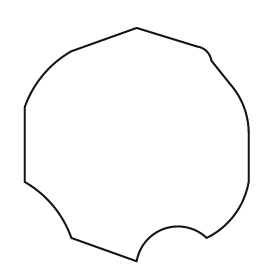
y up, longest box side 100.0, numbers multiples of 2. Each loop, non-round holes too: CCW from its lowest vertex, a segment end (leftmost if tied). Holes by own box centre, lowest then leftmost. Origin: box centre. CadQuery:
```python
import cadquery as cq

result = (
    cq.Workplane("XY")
    .moveTo(0.0, -50.0)
    .threePointArc((12.0, -36.0), (30.0, -40.0))
    .threePointArc((42.0, -30.0), (48.0, -16.0))
    .lineTo(48.0, 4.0)
    .threePointArc((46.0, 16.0), (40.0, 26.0))
    .lineTo(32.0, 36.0)
    .threePointArc((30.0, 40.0), (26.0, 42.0))
    .lineTo(0.0, 50.0)
    .lineTo(-28.0, 40.0)
    .threePointArc((-40.0, 30.0), (-48.0, 16.0))
    .lineTo(-48.0, -16.0)
    .threePointArc((-36.0, -26.0), (-28.0, -40.0))
    .close()
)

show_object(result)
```